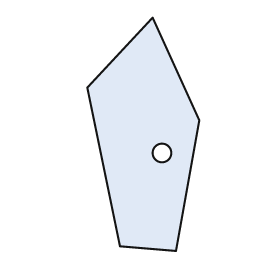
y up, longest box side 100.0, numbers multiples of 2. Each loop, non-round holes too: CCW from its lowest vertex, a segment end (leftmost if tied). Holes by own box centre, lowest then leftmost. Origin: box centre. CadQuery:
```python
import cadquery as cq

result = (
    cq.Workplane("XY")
    .moveTo(14.0, -50.0)
    .lineTo(24.0, 6.0)
    .lineTo(4.0, 50.0)
    .lineTo(-24.0, 20.0)
    .lineTo(-10.0, -48.0)
    .close()
    .moveTo(8.0, -8.0)
    .circle(4.0)
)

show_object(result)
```